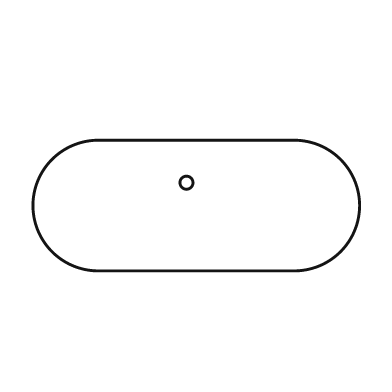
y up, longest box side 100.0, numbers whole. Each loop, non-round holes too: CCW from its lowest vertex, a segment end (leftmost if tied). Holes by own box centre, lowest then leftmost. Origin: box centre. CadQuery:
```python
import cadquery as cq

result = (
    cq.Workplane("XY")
    .moveTo(-30.0, -20.0)
    .lineTo(30.0, -20.0)
    .threePointArc((50.0, 0.0), (30.0, 20.0))
    .lineTo(-30.0, 20.0)
    .threePointArc((-50.0, 0.0), (-30.0, -20.0))
    .close()
    .moveTo(-3.0, 7.0)
    .circle(2.0)
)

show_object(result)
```